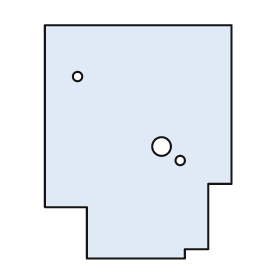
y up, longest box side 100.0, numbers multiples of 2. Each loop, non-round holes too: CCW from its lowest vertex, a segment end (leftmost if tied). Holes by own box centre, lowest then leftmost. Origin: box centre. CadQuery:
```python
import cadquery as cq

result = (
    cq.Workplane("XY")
    .moveTo(-22.0, -50.0)
    .lineTo(20.0, -50.0)
    .lineTo(20.0, -46.0)
    .lineTo(30.0, -46.0)
    .lineTo(30.0, -18.0)
    .lineTo(40.0, -18.0)
    .lineTo(40.0, 50.0)
    .lineTo(-40.0, 50.0)
    .lineTo(-40.0, -28.0)
    .lineTo(-22.0, -28.0)
    .close()
    .moveTo(18.0, -8.0)
    .circle(2.0)
    .moveTo(10.0, -2.0)
    .circle(4.0)
    .moveTo(-26.0, 28.0)
    .circle(2.0)
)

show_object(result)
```